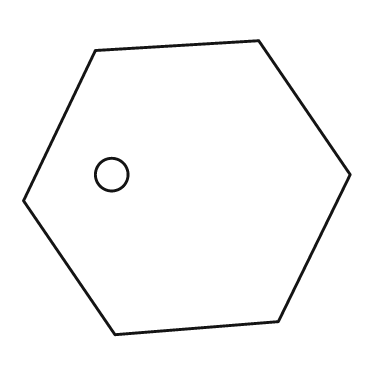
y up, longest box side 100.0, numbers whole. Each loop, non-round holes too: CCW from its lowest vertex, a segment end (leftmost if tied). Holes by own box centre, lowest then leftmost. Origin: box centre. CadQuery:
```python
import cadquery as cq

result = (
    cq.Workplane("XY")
    .moveTo(-22.0, -45.0)
    .lineTo(28.0, -41.0)
    .lineTo(50.0, 4.0)
    .lineTo(22.0, 45.0)
    .lineTo(-28.0, 42.0)
    .lineTo(-50.0, -4.0)
    .close()
    .moveTo(-23.0, 4.0)
    .circle(5.0)
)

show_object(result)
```